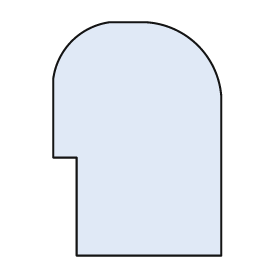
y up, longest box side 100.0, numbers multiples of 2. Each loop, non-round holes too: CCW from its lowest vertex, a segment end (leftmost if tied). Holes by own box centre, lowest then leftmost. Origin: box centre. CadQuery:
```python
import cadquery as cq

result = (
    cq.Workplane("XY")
    .moveTo(-26.0, -50.0)
    .lineTo(36.0, -50.0)
    .lineTo(36.0, 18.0)
    .threePointArc((26.0, 40.0), (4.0, 50.0))
    .lineTo(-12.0, 50.0)
    .threePointArc((-28.0, 42.0), (-36.0, 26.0))
    .lineTo(-36.0, -8.0)
    .lineTo(-26.0, -8.0)
    .close()
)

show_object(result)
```